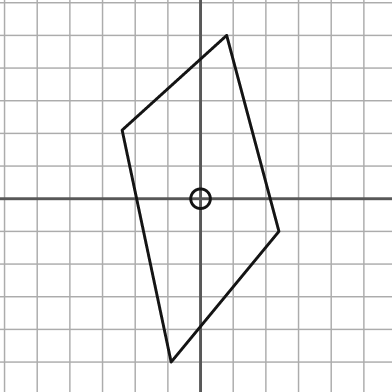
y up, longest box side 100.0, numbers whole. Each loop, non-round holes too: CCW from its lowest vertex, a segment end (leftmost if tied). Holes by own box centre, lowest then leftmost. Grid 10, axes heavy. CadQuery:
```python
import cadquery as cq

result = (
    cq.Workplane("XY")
    .moveTo(-9.0, -50.0)
    .lineTo(24.0, -10.0)
    .lineTo(8.0, 50.0)
    .lineTo(-24.0, 21.0)
    .close()
    .moveTo(0.0, 0.0)
    .circle(3.0)
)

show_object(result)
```